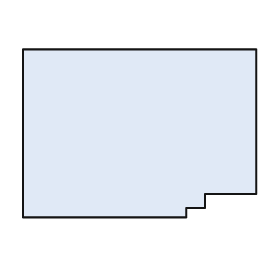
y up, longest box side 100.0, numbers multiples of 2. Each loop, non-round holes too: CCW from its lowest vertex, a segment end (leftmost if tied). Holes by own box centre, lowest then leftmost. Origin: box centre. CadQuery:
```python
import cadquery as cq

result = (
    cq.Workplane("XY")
    .moveTo(-50.0, -36.0)
    .lineTo(20.0, -36.0)
    .lineTo(20.0, -32.0)
    .lineTo(28.0, -32.0)
    .lineTo(28.0, -26.0)
    .lineTo(50.0, -26.0)
    .lineTo(50.0, 36.0)
    .lineTo(-50.0, 36.0)
    .close()
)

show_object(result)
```